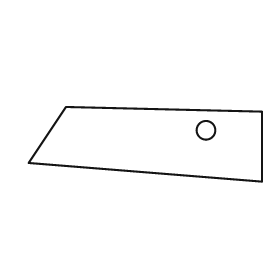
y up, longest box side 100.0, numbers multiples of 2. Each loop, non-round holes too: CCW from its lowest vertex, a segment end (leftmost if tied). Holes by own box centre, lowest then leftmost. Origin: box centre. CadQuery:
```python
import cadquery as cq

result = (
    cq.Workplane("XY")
    .moveTo(50.0, -16.0)
    .lineTo(50.0, 14.0)
    .lineTo(-34.0, 16.0)
    .lineTo(-50.0, -8.0)
    .close()
    .moveTo(26.0, 6.0)
    .circle(4.0)
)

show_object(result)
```